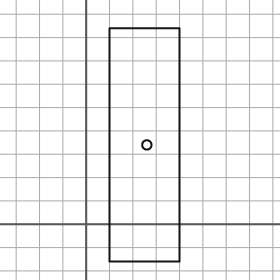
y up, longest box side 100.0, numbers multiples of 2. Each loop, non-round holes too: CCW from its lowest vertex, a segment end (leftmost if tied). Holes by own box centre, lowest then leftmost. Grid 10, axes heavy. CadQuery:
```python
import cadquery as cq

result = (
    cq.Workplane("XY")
    .moveTo(10.0, -16.0)
    .lineTo(40.0, -16.0)
    .lineTo(40.0, 84.0)
    .lineTo(10.0, 84.0)
    .close()
    .moveTo(26.0, 34.0)
    .circle(2.0)
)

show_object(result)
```